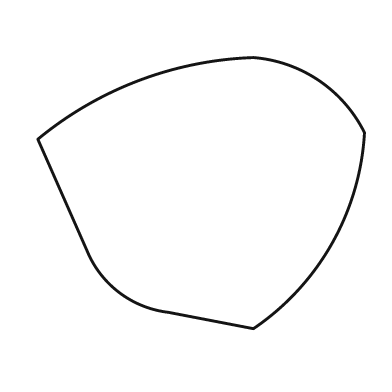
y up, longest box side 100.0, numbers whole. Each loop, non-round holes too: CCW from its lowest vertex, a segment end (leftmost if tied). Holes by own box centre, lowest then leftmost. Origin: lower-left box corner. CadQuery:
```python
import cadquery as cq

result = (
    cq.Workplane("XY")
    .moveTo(66.0, 0.0)
    .threePointArc((90.0, 26.0), (100.0, 60.0))
    .threePointArc((86.0, 76.0), (66.0, 83.0))
    .threePointArc((31.0, 76.0), (0.0, 58.0))
    .lineTo(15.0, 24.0)
    .threePointArc((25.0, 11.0), (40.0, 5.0))
    .close()
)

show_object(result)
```